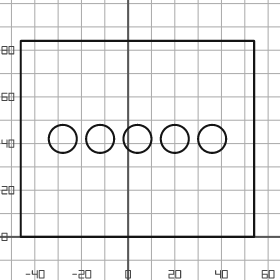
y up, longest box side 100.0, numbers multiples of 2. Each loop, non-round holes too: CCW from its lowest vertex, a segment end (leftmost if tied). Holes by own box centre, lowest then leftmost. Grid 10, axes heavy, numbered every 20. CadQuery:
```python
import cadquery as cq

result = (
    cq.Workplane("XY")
    .moveTo(-46.0, 0.0)
    .lineTo(54.0, 0.0)
    .lineTo(54.0, 84.0)
    .lineTo(-46.0, 84.0)
    .close()
    .moveTo(-28.0, 42.0)
    .circle(6.0)
    .moveTo(-12.0, 42.0)
    .circle(6.0)
    .moveTo(4.0, 42.0)
    .circle(6.0)
    .moveTo(20.0, 42.0)
    .circle(6.0)
    .moveTo(36.0, 42.0)
    .circle(6.0)
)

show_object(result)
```